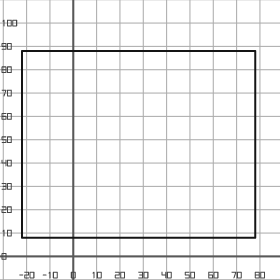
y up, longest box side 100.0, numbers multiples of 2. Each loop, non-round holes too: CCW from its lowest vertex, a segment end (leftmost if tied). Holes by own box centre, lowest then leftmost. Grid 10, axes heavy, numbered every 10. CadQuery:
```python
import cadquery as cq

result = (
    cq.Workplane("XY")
    .moveTo(-22.0, 8.0)
    .lineTo(78.0, 8.0)
    .lineTo(78.0, 88.0)
    .lineTo(-22.0, 88.0)
    .close()
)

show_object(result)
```